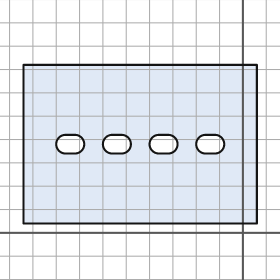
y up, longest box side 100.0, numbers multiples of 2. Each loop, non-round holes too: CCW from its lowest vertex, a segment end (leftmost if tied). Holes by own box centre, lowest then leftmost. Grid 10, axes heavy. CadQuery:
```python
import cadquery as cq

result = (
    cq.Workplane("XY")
    .moveTo(-94.0, 4.0)
    .lineTo(6.0, 4.0)
    .lineTo(6.0, 72.0)
    .lineTo(-94.0, 72.0)
    .close()
    .moveTo(-76.0, 34.0)
    .lineTo(-72.0, 34.0)
    .threePointArc((-68.0, 38.0), (-72.0, 42.0))
    .lineTo(-76.0, 42.0)
    .threePointArc((-80.0, 38.0), (-76.0, 34.0))
    .close()
    .moveTo(-56.0, 34.0)
    .lineTo(-52.0, 34.0)
    .threePointArc((-48.0, 38.0), (-52.0, 42.0))
    .lineTo(-56.0, 42.0)
    .threePointArc((-60.0, 38.0), (-56.0, 34.0))
    .close()
    .moveTo(-36.0, 34.0)
    .lineTo(-32.0, 34.0)
    .threePointArc((-28.0, 38.0), (-32.0, 42.0))
    .lineTo(-36.0, 42.0)
    .threePointArc((-40.0, 38.0), (-36.0, 34.0))
    .close()
    .moveTo(-16.0, 34.0)
    .lineTo(-12.0, 34.0)
    .threePointArc((-8.0, 38.0), (-12.0, 42.0))
    .lineTo(-16.0, 42.0)
    .threePointArc((-20.0, 38.0), (-16.0, 34.0))
    .close()
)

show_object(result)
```